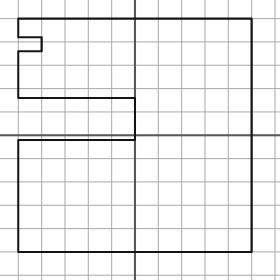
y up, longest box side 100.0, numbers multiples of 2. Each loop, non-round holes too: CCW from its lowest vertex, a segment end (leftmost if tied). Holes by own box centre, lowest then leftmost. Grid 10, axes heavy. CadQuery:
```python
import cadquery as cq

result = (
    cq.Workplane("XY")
    .moveTo(-50.0, -50.0)
    .lineTo(50.0, -50.0)
    .lineTo(50.0, 50.0)
    .lineTo(-50.0, 50.0)
    .lineTo(-50.0, 42.0)
    .lineTo(-40.0, 42.0)
    .lineTo(-40.0, 36.0)
    .lineTo(-50.0, 36.0)
    .lineTo(-50.0, 16.0)
    .lineTo(0.0, 16.0)
    .lineTo(0.0, -2.0)
    .lineTo(-50.0, -2.0)
    .close()
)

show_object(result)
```